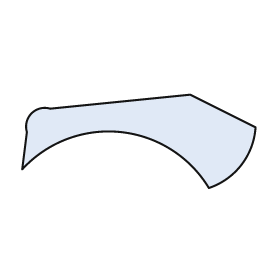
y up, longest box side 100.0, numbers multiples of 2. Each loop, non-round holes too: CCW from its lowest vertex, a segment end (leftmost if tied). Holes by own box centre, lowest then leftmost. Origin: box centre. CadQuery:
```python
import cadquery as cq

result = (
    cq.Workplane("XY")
    .moveTo(30.0, -20.0)
    .threePointArc((44.0, -10.0), (50.0, 6.0))
    .lineTo(22.0, 20.0)
    .lineTo(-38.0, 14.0)
    .threePointArc((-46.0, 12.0), (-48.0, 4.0))
    .lineTo(-50.0, -12.0)
    .threePointArc((-8.0, 4.0), (30.0, -20.0))
    .close()
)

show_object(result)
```